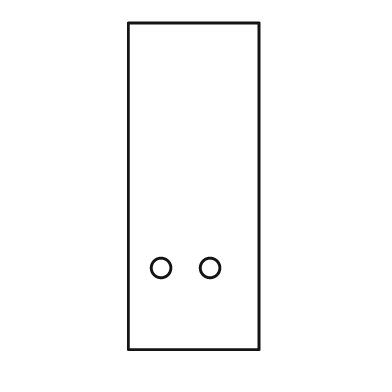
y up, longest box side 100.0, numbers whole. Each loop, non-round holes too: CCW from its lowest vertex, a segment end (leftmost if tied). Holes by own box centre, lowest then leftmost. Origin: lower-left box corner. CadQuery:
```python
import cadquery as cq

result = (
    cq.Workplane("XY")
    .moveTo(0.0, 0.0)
    .lineTo(40.0, 0.0)
    .lineTo(40.0, 100.0)
    .lineTo(0.0, 100.0)
    .close()
    .moveTo(10.0, 25.0)
    .circle(3.0)
    .moveTo(25.0, 25.0)
    .circle(3.0)
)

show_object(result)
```